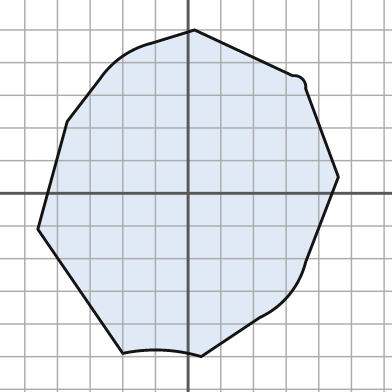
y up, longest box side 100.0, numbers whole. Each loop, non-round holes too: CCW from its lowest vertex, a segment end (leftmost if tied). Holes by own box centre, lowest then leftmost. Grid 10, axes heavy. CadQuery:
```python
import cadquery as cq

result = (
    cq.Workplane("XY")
    .moveTo(4.0, -50.0)
    .lineTo(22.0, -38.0)
    .threePointArc((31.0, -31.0), (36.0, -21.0))
    .lineTo(46.0, 5.0)
    .lineTo(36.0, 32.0)
    .threePointArc((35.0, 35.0), (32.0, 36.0))
    .lineTo(2.0, 50.0)
    .lineTo(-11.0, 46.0)
    .threePointArc((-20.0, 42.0), (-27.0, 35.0))
    .lineTo(-37.0, 22.0)
    .lineTo(-46.0, -11.0)
    .lineTo(-20.0, -49.0)
    .threePointArc((-8.0, -48.0), (4.0, -50.0))
    .close()
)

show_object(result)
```